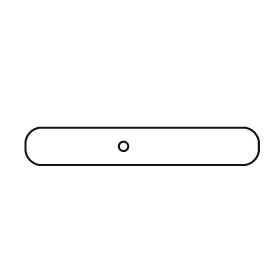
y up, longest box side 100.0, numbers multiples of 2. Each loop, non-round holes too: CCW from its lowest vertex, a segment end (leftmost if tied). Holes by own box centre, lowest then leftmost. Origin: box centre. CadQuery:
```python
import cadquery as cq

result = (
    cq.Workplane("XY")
    .moveTo(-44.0, -8.0)
    .lineTo(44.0, -8.0)
    .threePointArc((48.0, -6.0), (50.0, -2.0))
    .lineTo(50.0, 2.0)
    .threePointArc((48.0, 6.0), (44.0, 8.0))
    .lineTo(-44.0, 8.0)
    .threePointArc((-48.0, 6.0), (-50.0, 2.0))
    .lineTo(-50.0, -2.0)
    .threePointArc((-48.0, -6.0), (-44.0, -8.0))
    .close()
    .moveTo(-8.0, 0.0)
    .circle(2.0)
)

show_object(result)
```